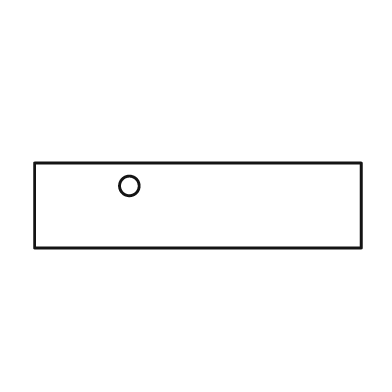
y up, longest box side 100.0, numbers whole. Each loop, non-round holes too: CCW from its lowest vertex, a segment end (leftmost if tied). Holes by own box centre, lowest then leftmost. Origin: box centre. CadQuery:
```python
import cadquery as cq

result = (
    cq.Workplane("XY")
    .moveTo(-50.0, -13.0)
    .lineTo(50.0, -13.0)
    .lineTo(50.0, 13.0)
    .lineTo(-50.0, 13.0)
    .close()
    .moveTo(-21.0, 6.0)
    .circle(3.0)
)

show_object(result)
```